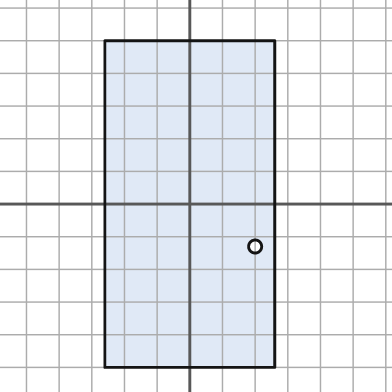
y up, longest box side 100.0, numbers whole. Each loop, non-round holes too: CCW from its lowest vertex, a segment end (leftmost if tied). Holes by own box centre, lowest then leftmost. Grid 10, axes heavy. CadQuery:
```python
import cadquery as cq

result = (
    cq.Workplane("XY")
    .moveTo(-26.0, -50.0)
    .lineTo(26.0, -50.0)
    .lineTo(26.0, 50.0)
    .lineTo(-26.0, 50.0)
    .close()
    .moveTo(20.0, -13.0)
    .circle(2.0)
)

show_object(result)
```